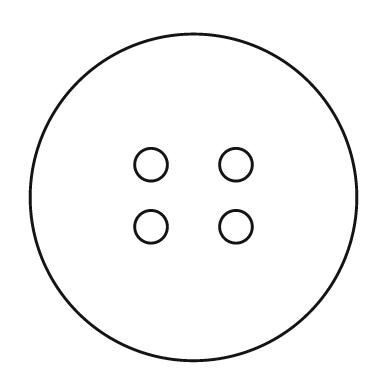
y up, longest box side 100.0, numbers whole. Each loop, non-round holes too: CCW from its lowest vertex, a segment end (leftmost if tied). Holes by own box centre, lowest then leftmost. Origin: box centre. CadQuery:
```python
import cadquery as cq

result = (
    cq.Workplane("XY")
    .moveTo(0.0, 0.0)
    .circle(50.0)
    .moveTo(-13.0, -9.0)
    .circle(5.0)
    .moveTo(13.0, -9.0)
    .circle(5.0)
    .moveTo(-13.0, 10.0)
    .circle(5.0)
    .moveTo(13.0, 10.0)
    .circle(5.0)
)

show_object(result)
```